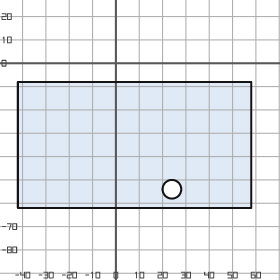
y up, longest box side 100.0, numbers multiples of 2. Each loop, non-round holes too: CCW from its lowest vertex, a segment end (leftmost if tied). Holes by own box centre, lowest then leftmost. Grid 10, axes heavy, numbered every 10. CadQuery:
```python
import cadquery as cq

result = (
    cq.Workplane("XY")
    .moveTo(-42.0, -62.0)
    .lineTo(58.0, -62.0)
    .lineTo(58.0, -8.0)
    .lineTo(-42.0, -8.0)
    .close()
    .moveTo(24.0, -54.0)
    .circle(4.0)
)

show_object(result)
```